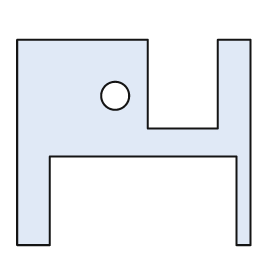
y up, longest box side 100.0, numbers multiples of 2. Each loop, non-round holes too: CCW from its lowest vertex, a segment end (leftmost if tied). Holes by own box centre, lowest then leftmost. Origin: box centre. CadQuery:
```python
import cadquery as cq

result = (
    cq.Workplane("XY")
    .moveTo(-50.0, -44.0)
    .lineTo(-36.0, -44.0)
    .lineTo(-36.0, -6.0)
    .lineTo(44.0, -6.0)
    .lineTo(44.0, -44.0)
    .lineTo(50.0, -44.0)
    .lineTo(50.0, 44.0)
    .lineTo(36.0, 44.0)
    .lineTo(36.0, 6.0)
    .lineTo(6.0, 6.0)
    .lineTo(6.0, 44.0)
    .lineTo(-50.0, 44.0)
    .close()
    .moveTo(-8.0, 20.0)
    .circle(6.0)
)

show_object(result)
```